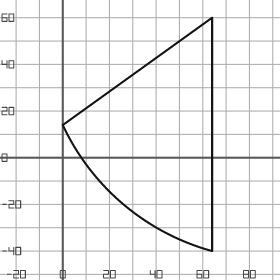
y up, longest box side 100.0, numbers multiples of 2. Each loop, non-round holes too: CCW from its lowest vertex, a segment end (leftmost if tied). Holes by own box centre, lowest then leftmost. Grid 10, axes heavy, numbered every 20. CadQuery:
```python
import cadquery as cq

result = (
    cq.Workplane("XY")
    .moveTo(64.0, -40.0)
    .lineTo(64.0, 60.0)
    .lineTo(0.0, 14.0)
    .threePointArc((26.0, -20.0), (64.0, -40.0))
    .close()
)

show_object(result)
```